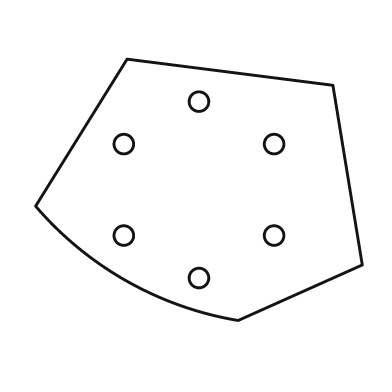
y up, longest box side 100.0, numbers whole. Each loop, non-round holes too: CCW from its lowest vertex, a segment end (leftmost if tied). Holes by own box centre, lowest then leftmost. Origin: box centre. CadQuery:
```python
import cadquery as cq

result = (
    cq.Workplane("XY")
    .moveTo(12.0, -40.0)
    .lineTo(50.0, -23.0)
    .lineTo(41.0, 32.0)
    .lineTo(-22.0, 40.0)
    .lineTo(-50.0, -5.0)
    .threePointArc((-22.0, -28.0), (12.0, -40.0))
    .close()
    .moveTo(0.0, -27.0)
    .circle(3.0)
    .moveTo(-23.0, -14.0)
    .circle(3.0)
    .moveTo(23.0, -14.0)
    .circle(3.0)
    .moveTo(-23.0, 14.0)
    .circle(3.0)
    .moveTo(23.0, 14.0)
    .circle(3.0)
    .moveTo(0.0, 27.0)
    .circle(3.0)
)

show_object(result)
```